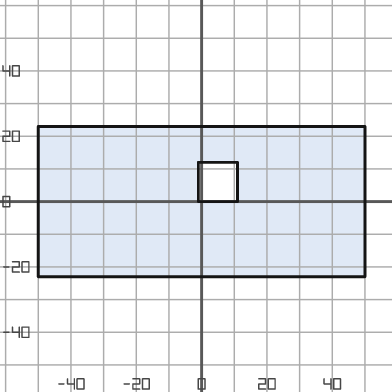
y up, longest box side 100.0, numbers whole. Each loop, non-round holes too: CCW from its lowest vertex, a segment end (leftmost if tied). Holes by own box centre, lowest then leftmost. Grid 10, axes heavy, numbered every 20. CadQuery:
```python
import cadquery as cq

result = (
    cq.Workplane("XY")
    .moveTo(-50.0, -23.0)
    .lineTo(50.0, -23.0)
    .lineTo(50.0, 23.0)
    .lineTo(-50.0, 23.0)
    .close()
    .moveTo(-1.0, 0.0)
    .lineTo(11.0, 0.0)
    .lineTo(11.0, 12.0)
    .lineTo(-1.0, 12.0)
    .close()
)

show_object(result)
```